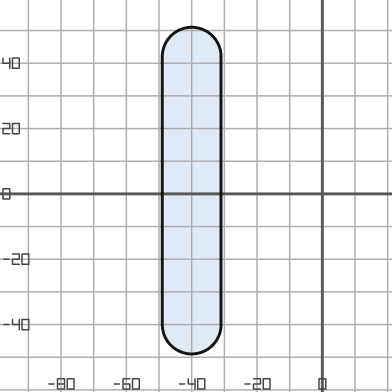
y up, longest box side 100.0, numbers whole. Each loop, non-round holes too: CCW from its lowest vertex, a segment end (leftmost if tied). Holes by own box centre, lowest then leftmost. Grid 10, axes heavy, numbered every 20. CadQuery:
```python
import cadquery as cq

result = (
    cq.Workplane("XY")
    .moveTo(-49.0, -40.0)
    .threePointArc((-40.0, -49.0), (-31.0, -40.0))
    .lineTo(-31.0, 42.0)
    .threePointArc((-40.0, 51.0), (-49.0, 42.0))
    .close()
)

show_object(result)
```